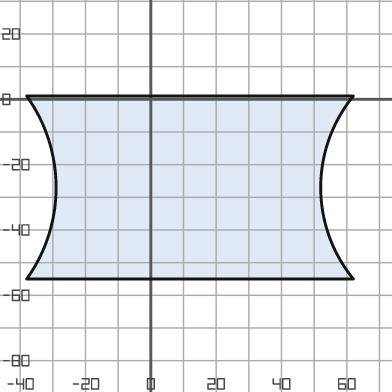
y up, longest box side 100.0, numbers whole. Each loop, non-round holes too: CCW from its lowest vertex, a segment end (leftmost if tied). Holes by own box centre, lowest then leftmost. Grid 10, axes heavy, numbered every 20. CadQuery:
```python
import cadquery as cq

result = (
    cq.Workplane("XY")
    .moveTo(-38.0, -55.0)
    .lineTo(62.0, -55.0)
    .threePointArc((52.0, -27.0), (62.0, 1.0))
    .lineTo(-38.0, 1.0)
    .threePointArc((-29.0, -27.0), (-38.0, -55.0))
    .close()
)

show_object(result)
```